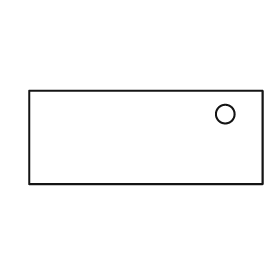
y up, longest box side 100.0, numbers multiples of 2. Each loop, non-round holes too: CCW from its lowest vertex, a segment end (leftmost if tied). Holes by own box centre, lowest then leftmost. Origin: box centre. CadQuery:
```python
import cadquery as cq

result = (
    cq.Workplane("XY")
    .moveTo(-50.0, -20.0)
    .lineTo(50.0, -20.0)
    .lineTo(50.0, 20.0)
    .lineTo(-50.0, 20.0)
    .close()
    .moveTo(34.0, 10.0)
    .circle(4.0)
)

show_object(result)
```